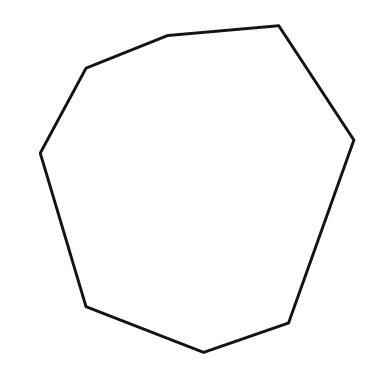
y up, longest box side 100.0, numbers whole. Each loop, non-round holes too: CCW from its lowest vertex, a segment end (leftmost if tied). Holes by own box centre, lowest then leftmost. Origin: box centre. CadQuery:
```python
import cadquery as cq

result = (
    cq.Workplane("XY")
    .moveTo(2.0, -50.0)
    .lineTo(28.0, -41.0)
    .lineTo(48.0, 15.0)
    .lineTo(25.0, 50.0)
    .lineTo(-9.0, 47.0)
    .lineTo(-34.0, 37.0)
    .lineTo(-48.0, 11.0)
    .lineTo(-34.0, -36.0)
    .close()
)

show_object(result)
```